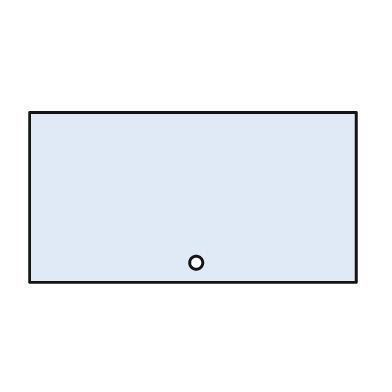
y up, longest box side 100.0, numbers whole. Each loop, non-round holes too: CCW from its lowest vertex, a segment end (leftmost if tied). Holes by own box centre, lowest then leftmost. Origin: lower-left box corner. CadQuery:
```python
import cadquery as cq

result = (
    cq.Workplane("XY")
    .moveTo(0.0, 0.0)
    .lineTo(100.0, 0.0)
    .lineTo(100.0, 52.0)
    .lineTo(0.0, 52.0)
    .close()
    .moveTo(51.0, 6.0)
    .circle(2.0)
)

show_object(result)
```